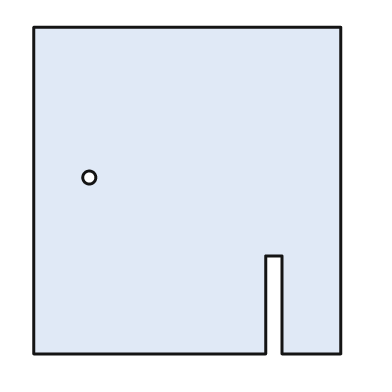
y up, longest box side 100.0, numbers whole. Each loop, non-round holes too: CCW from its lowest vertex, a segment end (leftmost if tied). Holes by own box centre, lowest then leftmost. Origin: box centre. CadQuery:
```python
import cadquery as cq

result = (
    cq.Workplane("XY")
    .moveTo(-47.0, -50.0)
    .lineTo(24.0, -50.0)
    .lineTo(24.0, -20.0)
    .lineTo(29.0, -20.0)
    .lineTo(29.0, -50.0)
    .lineTo(47.0, -50.0)
    .lineTo(47.0, 50.0)
    .lineTo(-47.0, 50.0)
    .close()
    .moveTo(-30.0, 4.0)
    .circle(2.0)
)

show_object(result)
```